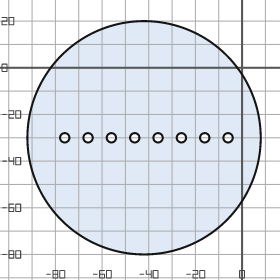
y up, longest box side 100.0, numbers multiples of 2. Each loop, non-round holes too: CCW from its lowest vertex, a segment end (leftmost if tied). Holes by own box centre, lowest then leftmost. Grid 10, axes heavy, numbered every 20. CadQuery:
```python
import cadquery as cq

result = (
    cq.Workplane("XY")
    .moveTo(-42.0, -30.0)
    .circle(50.0)
    .moveTo(-76.0, -30.0)
    .circle(2.0)
    .moveTo(-66.0, -30.0)
    .circle(2.0)
    .moveTo(-56.0, -30.0)
    .circle(2.0)
    .moveTo(-46.0, -30.0)
    .circle(2.0)
    .moveTo(-36.0, -30.0)
    .circle(2.0)
    .moveTo(-26.0, -30.0)
    .circle(2.0)
    .moveTo(-16.0, -30.0)
    .circle(2.0)
    .moveTo(-6.0, -30.0)
    .circle(2.0)
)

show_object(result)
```